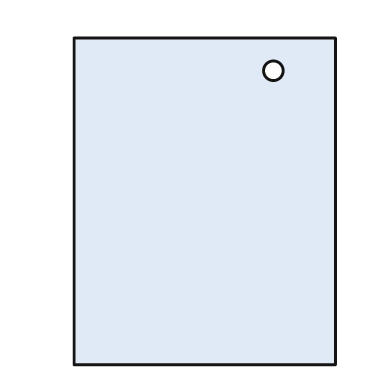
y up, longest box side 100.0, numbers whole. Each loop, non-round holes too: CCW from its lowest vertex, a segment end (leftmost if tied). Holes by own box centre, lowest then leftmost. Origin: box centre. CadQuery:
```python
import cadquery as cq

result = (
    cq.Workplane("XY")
    .moveTo(-40.0, -50.0)
    .lineTo(40.0, -50.0)
    .lineTo(40.0, 50.0)
    .lineTo(-40.0, 50.0)
    .close()
    .moveTo(21.0, 40.0)
    .circle(3.0)
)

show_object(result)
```